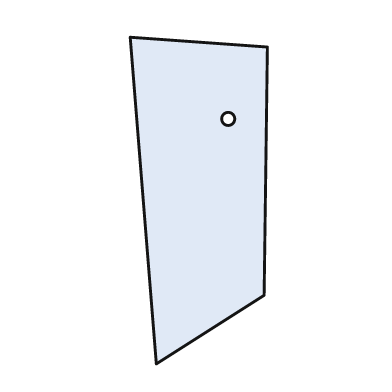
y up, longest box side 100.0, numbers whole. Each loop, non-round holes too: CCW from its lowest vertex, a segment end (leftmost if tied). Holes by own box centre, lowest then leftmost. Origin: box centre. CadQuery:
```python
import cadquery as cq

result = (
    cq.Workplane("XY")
    .moveTo(-13.0, -50.0)
    .lineTo(20.0, -29.0)
    .lineTo(21.0, 47.0)
    .lineTo(-21.0, 50.0)
    .close()
    .moveTo(9.0, 25.0)
    .circle(2.0)
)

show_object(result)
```